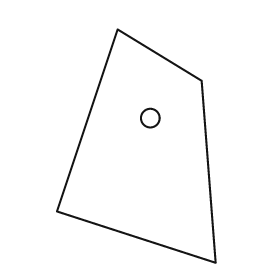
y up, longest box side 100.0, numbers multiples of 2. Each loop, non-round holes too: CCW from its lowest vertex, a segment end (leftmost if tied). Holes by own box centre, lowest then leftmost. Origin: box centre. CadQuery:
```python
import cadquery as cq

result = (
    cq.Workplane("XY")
    .moveTo(34.0, -50.0)
    .lineTo(28.0, 28.0)
    .lineTo(-8.0, 50.0)
    .lineTo(-34.0, -28.0)
    .close()
    .moveTo(6.0, 12.0)
    .circle(4.0)
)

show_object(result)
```